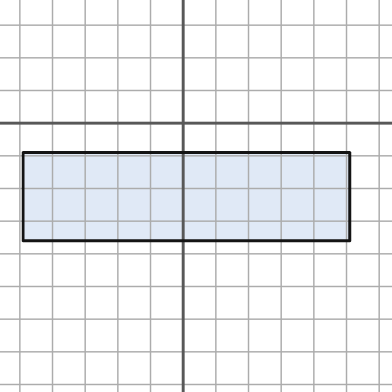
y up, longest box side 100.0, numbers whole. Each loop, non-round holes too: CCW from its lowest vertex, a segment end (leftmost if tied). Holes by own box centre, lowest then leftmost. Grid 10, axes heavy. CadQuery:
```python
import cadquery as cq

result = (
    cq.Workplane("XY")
    .moveTo(-49.0, -36.0)
    .lineTo(51.0, -36.0)
    .lineTo(51.0, -9.0)
    .lineTo(-49.0, -9.0)
    .close()
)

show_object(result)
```